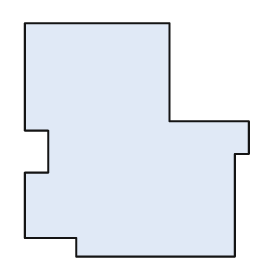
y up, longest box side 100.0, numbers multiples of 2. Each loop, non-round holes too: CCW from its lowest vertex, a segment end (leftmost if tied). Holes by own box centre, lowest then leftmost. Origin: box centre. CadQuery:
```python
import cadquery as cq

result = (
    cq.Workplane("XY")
    .moveTo(-26.0, -50.0)
    .lineTo(42.0, -50.0)
    .lineTo(42.0, -6.0)
    .lineTo(48.0, -6.0)
    .lineTo(48.0, 8.0)
    .lineTo(14.0, 8.0)
    .lineTo(14.0, 50.0)
    .lineTo(-48.0, 50.0)
    .lineTo(-48.0, 4.0)
    .lineTo(-38.0, 4.0)
    .lineTo(-38.0, -14.0)
    .lineTo(-48.0, -14.0)
    .lineTo(-48.0, -42.0)
    .lineTo(-26.0, -42.0)
    .close()
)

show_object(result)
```